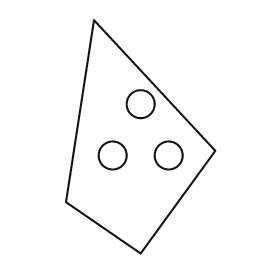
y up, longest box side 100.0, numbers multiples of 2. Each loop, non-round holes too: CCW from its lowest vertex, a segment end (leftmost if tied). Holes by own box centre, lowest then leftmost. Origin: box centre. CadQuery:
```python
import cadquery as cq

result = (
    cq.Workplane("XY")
    .moveTo(0.0, -50.0)
    .lineTo(32.0, -6.0)
    .lineTo(-20.0, 50.0)
    .lineTo(-32.0, -28.0)
    .close()
    .moveTo(-12.0, -8.0)
    .circle(6.0)
    .moveTo(12.0, -8.0)
    .circle(6.0)
    .moveTo(0.0, 14.0)
    .circle(6.0)
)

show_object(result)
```